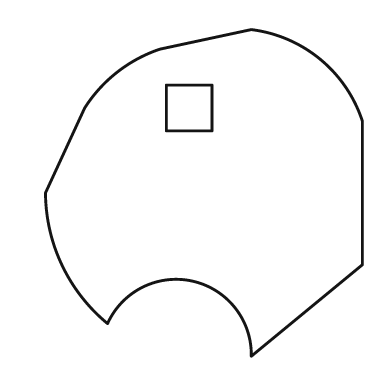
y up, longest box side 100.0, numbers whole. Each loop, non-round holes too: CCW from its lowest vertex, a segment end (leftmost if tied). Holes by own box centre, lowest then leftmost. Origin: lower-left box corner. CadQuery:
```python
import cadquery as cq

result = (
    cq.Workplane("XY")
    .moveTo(63.0, 0.0)
    .lineTo(97.0, 28.0)
    .lineTo(97.0, 72.0)
    .threePointArc((84.0, 91.0), (63.0, 100.0))
    .lineTo(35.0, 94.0)
    .threePointArc((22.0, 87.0), (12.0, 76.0))
    .lineTo(0.0, 50.0)
    .threePointArc((5.0, 28.0), (19.0, 10.0))
    .threePointArc((45.0, 23.0), (63.0, 0.0))
    .close()
    .moveTo(37.0, 69.0)
    .lineTo(51.0, 69.0)
    .lineTo(51.0, 83.0)
    .lineTo(37.0, 83.0)
    .close()
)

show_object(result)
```